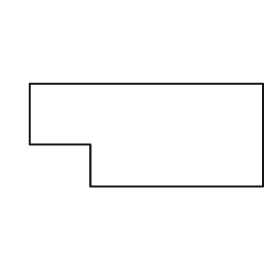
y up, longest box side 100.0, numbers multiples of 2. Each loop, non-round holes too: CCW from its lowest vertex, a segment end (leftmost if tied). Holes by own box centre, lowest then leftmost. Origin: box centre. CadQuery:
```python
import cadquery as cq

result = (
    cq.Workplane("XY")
    .moveTo(-24.0, -22.0)
    .lineTo(50.0, -22.0)
    .lineTo(50.0, 22.0)
    .lineTo(-50.0, 22.0)
    .lineTo(-50.0, -4.0)
    .lineTo(-24.0, -4.0)
    .close()
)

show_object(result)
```